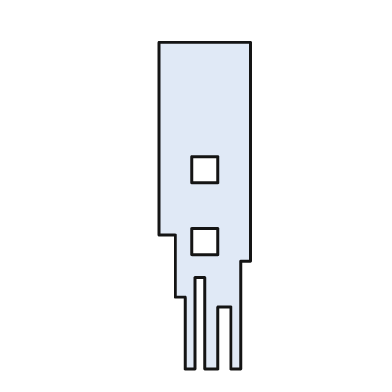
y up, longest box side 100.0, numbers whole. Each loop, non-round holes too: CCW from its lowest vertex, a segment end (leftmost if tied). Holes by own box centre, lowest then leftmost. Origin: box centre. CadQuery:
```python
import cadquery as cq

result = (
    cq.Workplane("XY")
    .moveTo(-6.0, -50.0)
    .lineTo(-3.0, -50.0)
    .lineTo(-3.0, -22.0)
    .lineTo(0.0, -22.0)
    .lineTo(0.0, -50.0)
    .lineTo(4.0, -50.0)
    .lineTo(4.0, -31.0)
    .lineTo(8.0, -31.0)
    .lineTo(8.0, -50.0)
    .lineTo(11.0, -50.0)
    .lineTo(11.0, -17.0)
    .lineTo(14.0, -17.0)
    .lineTo(14.0, 50.0)
    .lineTo(-14.0, 50.0)
    .lineTo(-14.0, -9.0)
    .lineTo(-9.0, -9.0)
    .lineTo(-9.0, -28.0)
    .lineTo(-6.0, -28.0)
    .close()
    .moveTo(-4.0, -15.0)
    .lineTo(4.0, -15.0)
    .lineTo(4.0, -7.0)
    .lineTo(-4.0, -7.0)
    .close()
    .moveTo(-4.0, 7.0)
    .lineTo(4.0, 7.0)
    .lineTo(4.0, 15.0)
    .lineTo(-4.0, 15.0)
    .close()
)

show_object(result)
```